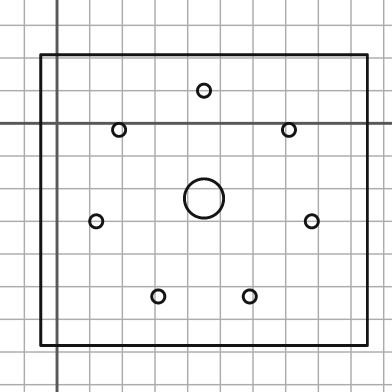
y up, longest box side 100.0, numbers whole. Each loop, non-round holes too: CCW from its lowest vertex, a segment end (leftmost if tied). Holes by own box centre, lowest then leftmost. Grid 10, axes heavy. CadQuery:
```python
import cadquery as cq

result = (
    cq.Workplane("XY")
    .moveTo(-5.0, -68.0)
    .lineTo(95.0, -68.0)
    .lineTo(95.0, 21.0)
    .lineTo(-5.0, 21.0)
    .close()
    .moveTo(31.0, -53.0)
    .circle(2.0)
    .moveTo(59.0, -53.0)
    .circle(2.0)
    .moveTo(12.0, -30.0)
    .circle(2.0)
    .moveTo(78.0, -30.0)
    .circle(2.0)
    .moveTo(45.0, -23.0)
    .circle(6.0)
    .moveTo(19.0, -2.0)
    .circle(2.0)
    .moveTo(71.0, -2.0)
    .circle(2.0)
    .moveTo(45.0, 10.0)
    .circle(2.0)
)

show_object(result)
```